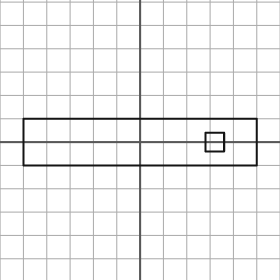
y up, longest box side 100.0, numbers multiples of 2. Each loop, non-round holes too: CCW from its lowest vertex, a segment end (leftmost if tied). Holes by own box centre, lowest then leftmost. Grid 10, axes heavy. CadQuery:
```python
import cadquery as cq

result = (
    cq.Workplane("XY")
    .moveTo(-50.0, -10.0)
    .lineTo(50.0, -10.0)
    .lineTo(50.0, 10.0)
    .lineTo(-50.0, 10.0)
    .close()
    .moveTo(28.0, -4.0)
    .lineTo(36.0, -4.0)
    .lineTo(36.0, 4.0)
    .lineTo(28.0, 4.0)
    .close()
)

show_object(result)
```